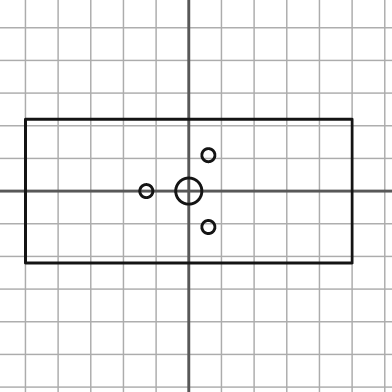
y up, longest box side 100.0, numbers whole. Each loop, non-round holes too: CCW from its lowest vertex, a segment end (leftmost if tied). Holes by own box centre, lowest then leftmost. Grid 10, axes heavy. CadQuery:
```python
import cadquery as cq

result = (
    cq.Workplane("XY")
    .moveTo(-50.0, -22.0)
    .lineTo(50.0, -22.0)
    .lineTo(50.0, 22.0)
    .lineTo(-50.0, 22.0)
    .close()
    .moveTo(6.0, -11.0)
    .circle(2.0)
    .moveTo(-13.0, 0.0)
    .circle(2.0)
    .moveTo(0.0, 0.0)
    .circle(4.0)
    .moveTo(6.0, 11.0)
    .circle(2.0)
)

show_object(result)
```